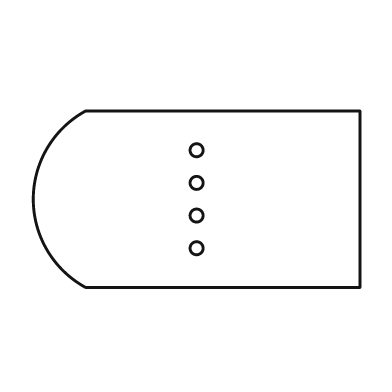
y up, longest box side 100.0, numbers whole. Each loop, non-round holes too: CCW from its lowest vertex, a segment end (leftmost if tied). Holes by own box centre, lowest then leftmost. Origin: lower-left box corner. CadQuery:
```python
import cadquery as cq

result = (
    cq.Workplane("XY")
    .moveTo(16.0, 0.0)
    .lineTo(100.0, 0.0)
    .lineTo(100.0, 54.0)
    .lineTo(16.0, 54.0)
    .threePointArc((0.0, 27.0), (16.0, 0.0))
    .close()
    .moveTo(50.0, 12.0)
    .circle(2.0)
    .moveTo(50.0, 22.0)
    .circle(2.0)
    .moveTo(50.0, 32.0)
    .circle(2.0)
    .moveTo(50.0, 42.0)
    .circle(2.0)
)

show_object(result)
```